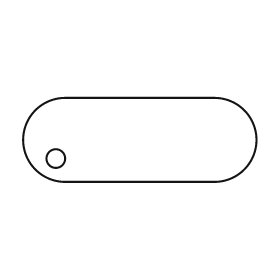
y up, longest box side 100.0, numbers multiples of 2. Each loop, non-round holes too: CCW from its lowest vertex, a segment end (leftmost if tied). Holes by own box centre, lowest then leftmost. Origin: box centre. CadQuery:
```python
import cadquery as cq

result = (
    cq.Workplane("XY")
    .moveTo(-32.0, -18.0)
    .lineTo(32.0, -18.0)
    .threePointArc((50.0, 0.0), (32.0, 18.0))
    .lineTo(-32.0, 18.0)
    .threePointArc((-50.0, 0.0), (-32.0, -18.0))
    .close()
    .moveTo(-36.0, -8.0)
    .circle(4.0)
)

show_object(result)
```